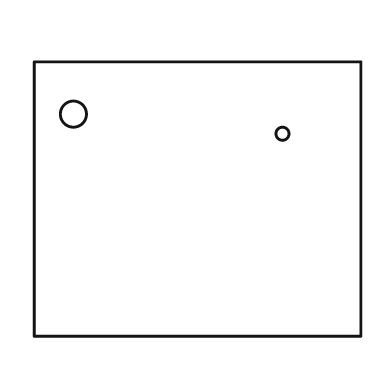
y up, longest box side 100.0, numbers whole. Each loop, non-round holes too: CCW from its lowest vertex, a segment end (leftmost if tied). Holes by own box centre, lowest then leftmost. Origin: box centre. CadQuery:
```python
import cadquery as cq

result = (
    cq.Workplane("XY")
    .moveTo(-50.0, -42.0)
    .lineTo(50.0, -42.0)
    .lineTo(50.0, 42.0)
    .lineTo(-50.0, 42.0)
    .close()
    .moveTo(26.0, 20.0)
    .circle(2.0)
    .moveTo(-38.0, 26.0)
    .circle(4.0)
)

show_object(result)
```